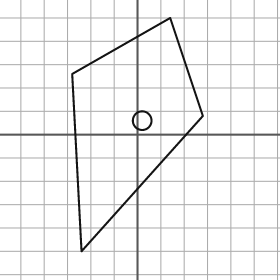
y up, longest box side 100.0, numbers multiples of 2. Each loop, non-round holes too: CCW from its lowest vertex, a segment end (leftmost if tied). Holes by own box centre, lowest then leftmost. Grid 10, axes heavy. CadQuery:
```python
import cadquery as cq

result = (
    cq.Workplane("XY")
    .moveTo(-24.0, -50.0)
    .lineTo(28.0, 8.0)
    .lineTo(14.0, 50.0)
    .lineTo(-28.0, 26.0)
    .close()
    .moveTo(2.0, 6.0)
    .circle(4.0)
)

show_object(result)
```